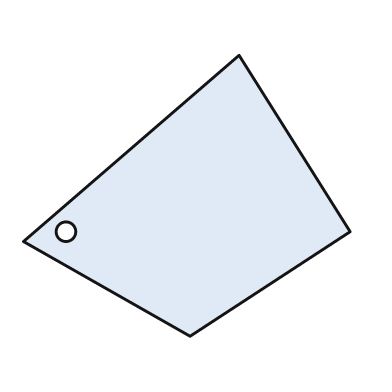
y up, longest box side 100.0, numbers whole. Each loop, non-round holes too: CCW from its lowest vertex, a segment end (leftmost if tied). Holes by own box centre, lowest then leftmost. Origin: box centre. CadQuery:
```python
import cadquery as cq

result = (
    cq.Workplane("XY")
    .moveTo(1.0, -43.0)
    .lineTo(50.0, -11.0)
    .lineTo(16.0, 43.0)
    .lineTo(-50.0, -14.0)
    .close()
    .moveTo(-37.0, -11.0)
    .circle(3.0)
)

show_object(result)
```